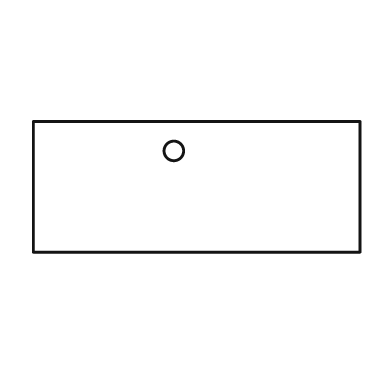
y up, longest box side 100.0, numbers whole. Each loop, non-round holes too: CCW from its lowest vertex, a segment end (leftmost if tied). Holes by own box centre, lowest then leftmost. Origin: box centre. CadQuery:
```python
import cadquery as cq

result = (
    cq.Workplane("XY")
    .moveTo(-50.0, -20.0)
    .lineTo(50.0, -20.0)
    .lineTo(50.0, 20.0)
    .lineTo(-50.0, 20.0)
    .close()
    .moveTo(-7.0, 11.0)
    .circle(3.0)
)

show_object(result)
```